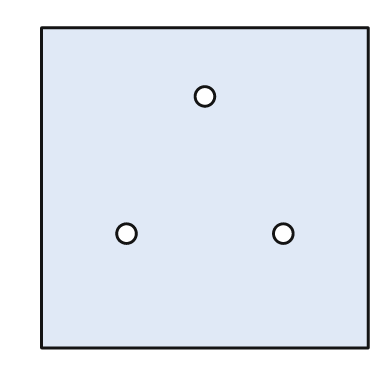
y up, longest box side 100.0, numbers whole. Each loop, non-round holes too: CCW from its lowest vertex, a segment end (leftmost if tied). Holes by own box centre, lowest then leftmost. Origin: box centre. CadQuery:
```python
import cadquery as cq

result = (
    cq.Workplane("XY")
    .moveTo(-50.0, -49.0)
    .lineTo(50.0, -49.0)
    .lineTo(50.0, 49.0)
    .lineTo(-50.0, 49.0)
    .close()
    .moveTo(-24.0, -14.0)
    .circle(3.0)
    .moveTo(24.0, -14.0)
    .circle(3.0)
    .moveTo(0.0, 28.0)
    .circle(3.0)
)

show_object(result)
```